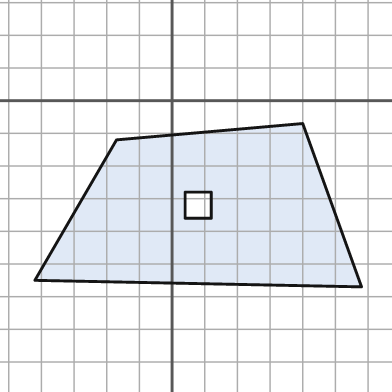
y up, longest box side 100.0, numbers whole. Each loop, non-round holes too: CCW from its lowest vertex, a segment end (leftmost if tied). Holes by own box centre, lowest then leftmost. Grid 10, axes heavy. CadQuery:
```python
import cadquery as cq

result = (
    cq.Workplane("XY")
    .moveTo(58.0, -57.0)
    .lineTo(40.0, -7.0)
    .lineTo(-17.0, -12.0)
    .lineTo(-42.0, -55.0)
    .close()
    .moveTo(4.0, -36.0)
    .lineTo(12.0, -36.0)
    .lineTo(12.0, -28.0)
    .lineTo(4.0, -28.0)
    .close()
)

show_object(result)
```